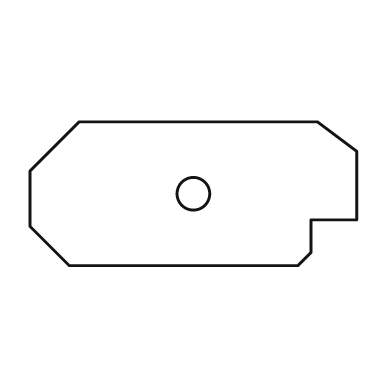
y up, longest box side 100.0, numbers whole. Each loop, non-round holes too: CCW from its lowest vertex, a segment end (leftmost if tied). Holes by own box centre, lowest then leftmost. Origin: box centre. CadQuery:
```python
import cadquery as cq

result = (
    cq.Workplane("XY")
    .moveTo(-38.0, -22.0)
    .lineTo(32.0, -22.0)
    .lineTo(36.0, -18.0)
    .lineTo(36.0, -8.0)
    .lineTo(50.0, -8.0)
    .lineTo(50.0, 13.0)
    .lineTo(38.0, 22.0)
    .lineTo(-35.0, 22.0)
    .lineTo(-50.0, 7.0)
    .lineTo(-50.0, -10.0)
    .close()
    .moveTo(0.0, 0.0)
    .circle(5.0)
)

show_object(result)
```